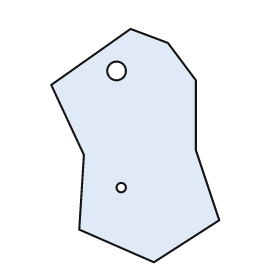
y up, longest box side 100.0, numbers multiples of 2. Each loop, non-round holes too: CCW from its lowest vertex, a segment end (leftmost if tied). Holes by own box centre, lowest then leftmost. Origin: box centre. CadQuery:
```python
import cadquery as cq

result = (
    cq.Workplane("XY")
    .moveTo(8.0, -50.0)
    .lineTo(36.0, -32.0)
    .lineTo(26.0, -2.0)
    .lineTo(26.0, 28.0)
    .lineTo(14.0, 44.0)
    .lineTo(-2.0, 50.0)
    .lineTo(-36.0, 26.0)
    .lineTo(-22.0, -4.0)
    .lineTo(-24.0, -36.0)
    .close()
    .moveTo(-6.0, -18.0)
    .circle(2.0)
    .moveTo(-8.0, 32.0)
    .circle(4.0)
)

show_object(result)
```